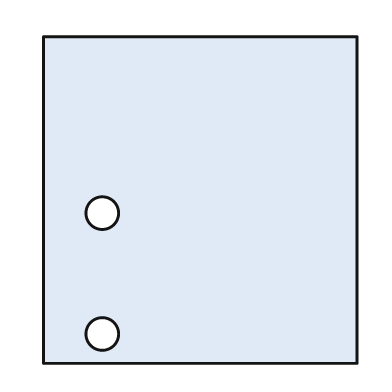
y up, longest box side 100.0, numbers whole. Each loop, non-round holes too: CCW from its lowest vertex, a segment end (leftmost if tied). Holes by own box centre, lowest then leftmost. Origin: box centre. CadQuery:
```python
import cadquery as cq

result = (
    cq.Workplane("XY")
    .moveTo(-48.0, -50.0)
    .lineTo(48.0, -50.0)
    .lineTo(48.0, 50.0)
    .lineTo(-48.0, 50.0)
    .close()
    .moveTo(-30.0, -41.0)
    .circle(5.0)
    .moveTo(-30.0, -4.0)
    .circle(5.0)
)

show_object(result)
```